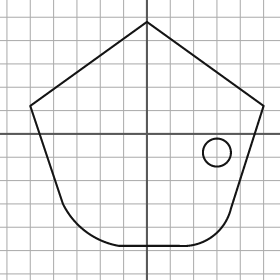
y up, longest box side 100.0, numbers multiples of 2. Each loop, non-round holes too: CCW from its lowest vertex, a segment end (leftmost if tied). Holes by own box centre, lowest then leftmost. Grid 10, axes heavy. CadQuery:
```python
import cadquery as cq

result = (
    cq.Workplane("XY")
    .moveTo(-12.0, -48.0)
    .lineTo(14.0, -48.0)
    .threePointArc((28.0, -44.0), (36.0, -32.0))
    .lineTo(50.0, 12.0)
    .lineTo(0.0, 48.0)
    .lineTo(-50.0, 12.0)
    .lineTo(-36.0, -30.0)
    .threePointArc((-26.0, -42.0), (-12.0, -48.0))
    .close()
    .moveTo(30.0, -8.0)
    .circle(6.0)
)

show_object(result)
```